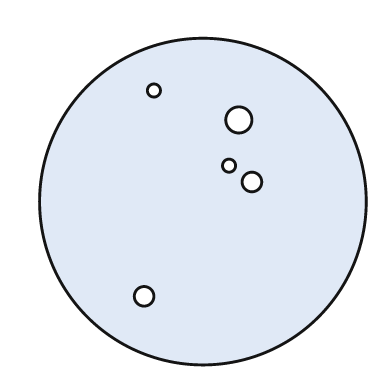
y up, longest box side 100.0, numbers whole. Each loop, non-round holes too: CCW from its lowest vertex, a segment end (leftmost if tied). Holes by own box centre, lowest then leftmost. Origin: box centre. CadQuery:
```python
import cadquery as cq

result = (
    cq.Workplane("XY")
    .moveTo(0.0, 0.0)
    .circle(50.0)
    .moveTo(-18.0, -29.0)
    .circle(3.0)
    .moveTo(15.0, 6.0)
    .circle(3.0)
    .moveTo(8.0, 11.0)
    .circle(2.0)
    .moveTo(11.0, 25.0)
    .circle(4.0)
    .moveTo(-15.0, 34.0)
    .circle(2.0)
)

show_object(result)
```